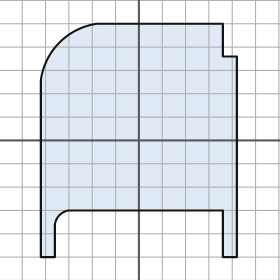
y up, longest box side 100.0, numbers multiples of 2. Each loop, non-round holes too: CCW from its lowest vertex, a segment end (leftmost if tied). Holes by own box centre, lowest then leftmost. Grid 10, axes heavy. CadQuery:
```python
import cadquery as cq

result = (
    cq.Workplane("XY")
    .moveTo(-42.0, -50.0)
    .lineTo(-36.0, -50.0)
    .lineTo(-36.0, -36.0)
    .threePointArc((-34.0, -32.0), (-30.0, -30.0))
    .lineTo(36.0, -30.0)
    .lineTo(36.0, -50.0)
    .lineTo(42.0, -50.0)
    .lineTo(42.0, 36.0)
    .lineTo(36.0, 36.0)
    .lineTo(36.0, 50.0)
    .lineTo(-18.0, 50.0)
    .threePointArc((-34.0, 42.0), (-42.0, 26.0))
    .close()
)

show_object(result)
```